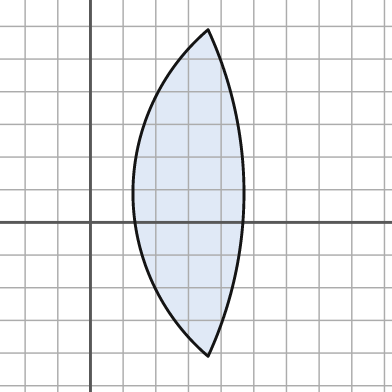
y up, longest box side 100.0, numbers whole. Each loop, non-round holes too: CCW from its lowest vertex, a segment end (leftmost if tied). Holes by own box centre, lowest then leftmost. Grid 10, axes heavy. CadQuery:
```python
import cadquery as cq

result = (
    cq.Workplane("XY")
    .moveTo(36.0, -41.0)
    .threePointArc((47.0, 9.0), (36.0, 59.0))
    .threePointArc((13.0, 9.0), (36.0, -41.0))
    .close()
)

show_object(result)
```